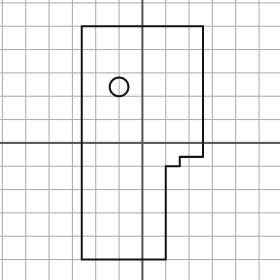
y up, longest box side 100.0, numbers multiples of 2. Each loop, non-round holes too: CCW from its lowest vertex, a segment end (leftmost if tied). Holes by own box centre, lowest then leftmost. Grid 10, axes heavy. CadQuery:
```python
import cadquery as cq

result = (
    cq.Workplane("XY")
    .moveTo(-26.0, -50.0)
    .lineTo(10.0, -50.0)
    .lineTo(10.0, -10.0)
    .lineTo(16.0, -10.0)
    .lineTo(16.0, -6.0)
    .lineTo(26.0, -6.0)
    .lineTo(26.0, 50.0)
    .lineTo(-26.0, 50.0)
    .close()
    .moveTo(-10.0, 24.0)
    .circle(4.0)
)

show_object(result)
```